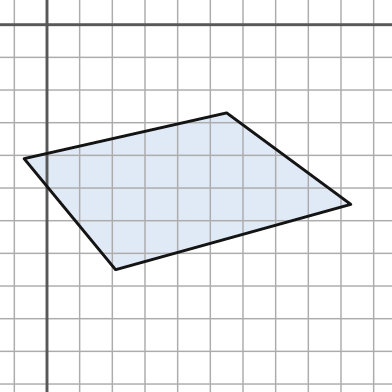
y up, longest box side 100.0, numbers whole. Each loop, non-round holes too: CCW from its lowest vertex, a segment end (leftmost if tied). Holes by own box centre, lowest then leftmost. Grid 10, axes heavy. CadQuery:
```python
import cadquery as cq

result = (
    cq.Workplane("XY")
    .moveTo(21.0, -75.0)
    .lineTo(93.0, -55.0)
    .lineTo(55.0, -27.0)
    .lineTo(-7.0, -41.0)
    .close()
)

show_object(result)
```